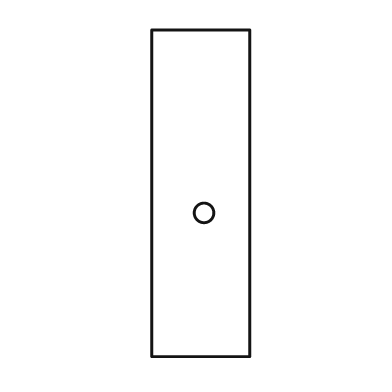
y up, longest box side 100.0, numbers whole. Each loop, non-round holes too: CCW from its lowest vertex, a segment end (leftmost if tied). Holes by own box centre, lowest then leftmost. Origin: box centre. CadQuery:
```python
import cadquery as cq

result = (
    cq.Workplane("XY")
    .moveTo(-15.0, -50.0)
    .lineTo(15.0, -50.0)
    .lineTo(15.0, 50.0)
    .lineTo(-15.0, 50.0)
    .close()
    .moveTo(1.0, -6.0)
    .circle(3.0)
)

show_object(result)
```